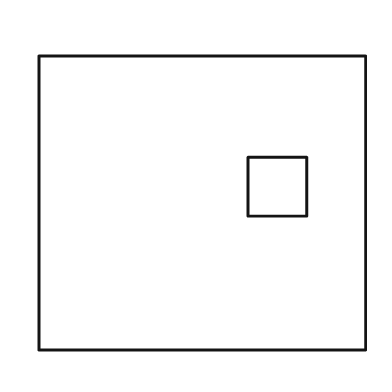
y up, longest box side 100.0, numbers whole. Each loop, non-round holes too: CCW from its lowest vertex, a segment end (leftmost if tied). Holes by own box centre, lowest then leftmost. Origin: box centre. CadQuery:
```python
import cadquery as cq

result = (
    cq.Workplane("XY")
    .moveTo(-50.0, -45.0)
    .lineTo(50.0, -45.0)
    .lineTo(50.0, 45.0)
    .lineTo(-50.0, 45.0)
    .close()
    .moveTo(14.0, -4.0)
    .lineTo(32.0, -4.0)
    .lineTo(32.0, 14.0)
    .lineTo(14.0, 14.0)
    .close()
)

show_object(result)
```